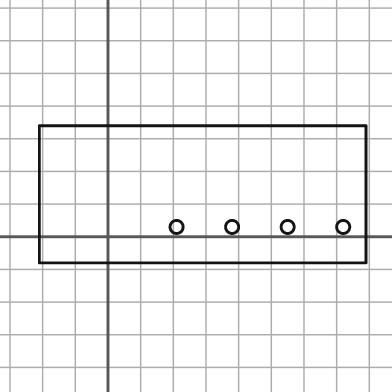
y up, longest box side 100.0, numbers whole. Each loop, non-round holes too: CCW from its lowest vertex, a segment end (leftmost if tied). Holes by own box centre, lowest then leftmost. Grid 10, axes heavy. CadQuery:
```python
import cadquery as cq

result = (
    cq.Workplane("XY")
    .moveTo(-21.0, -8.0)
    .lineTo(79.0, -8.0)
    .lineTo(79.0, 34.0)
    .lineTo(-21.0, 34.0)
    .close()
    .moveTo(21.0, 3.0)
    .circle(2.0)
    .moveTo(38.0, 3.0)
    .circle(2.0)
    .moveTo(55.0, 3.0)
    .circle(2.0)
    .moveTo(72.0, 3.0)
    .circle(2.0)
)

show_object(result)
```